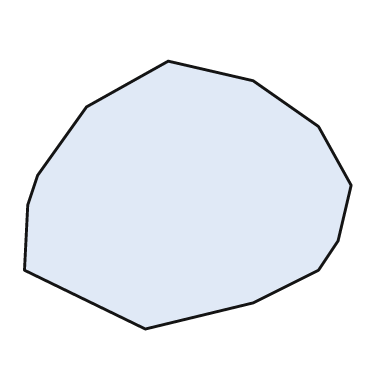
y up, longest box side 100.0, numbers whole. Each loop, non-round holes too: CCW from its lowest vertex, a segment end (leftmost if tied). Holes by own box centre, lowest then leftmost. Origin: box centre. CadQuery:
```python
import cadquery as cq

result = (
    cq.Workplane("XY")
    .moveTo(-13.0, -41.0)
    .lineTo(20.0, -33.0)
    .lineTo(40.0, -23.0)
    .lineTo(46.0, -14.0)
    .lineTo(50.0, 3.0)
    .lineTo(40.0, 21.0)
    .lineTo(20.0, 35.0)
    .lineTo(-6.0, 41.0)
    .lineTo(-31.0, 27.0)
    .lineTo(-46.0, 6.0)
    .lineTo(-49.0, -3.0)
    .lineTo(-50.0, -23.0)
    .close()
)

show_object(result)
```